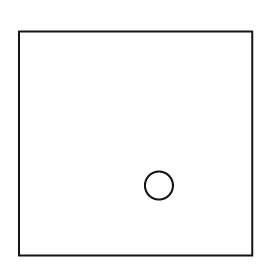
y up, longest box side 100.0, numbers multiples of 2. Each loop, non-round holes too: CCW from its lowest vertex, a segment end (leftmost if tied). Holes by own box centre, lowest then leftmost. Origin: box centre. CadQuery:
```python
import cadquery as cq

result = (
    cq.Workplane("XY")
    .moveTo(-50.0, -48.0)
    .lineTo(50.0, -48.0)
    .lineTo(50.0, 48.0)
    .lineTo(-50.0, 48.0)
    .close()
    .moveTo(10.0, -18.0)
    .circle(6.0)
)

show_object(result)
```